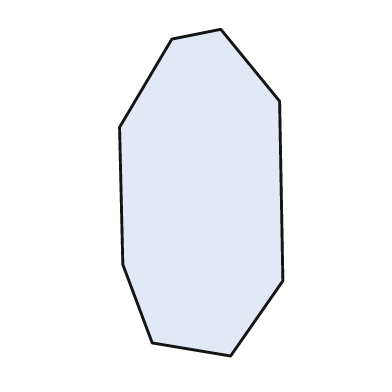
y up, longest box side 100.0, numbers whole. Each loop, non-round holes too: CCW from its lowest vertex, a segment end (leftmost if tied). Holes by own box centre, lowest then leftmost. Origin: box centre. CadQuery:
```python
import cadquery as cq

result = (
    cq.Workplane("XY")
    .moveTo(9.0, -50.0)
    .lineTo(25.0, -27.0)
    .lineTo(24.0, 28.0)
    .lineTo(6.0, 50.0)
    .lineTo(-9.0, 47.0)
    .lineTo(-25.0, 20.0)
    .lineTo(-24.0, -22.0)
    .lineTo(-15.0, -46.0)
    .close()
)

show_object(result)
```